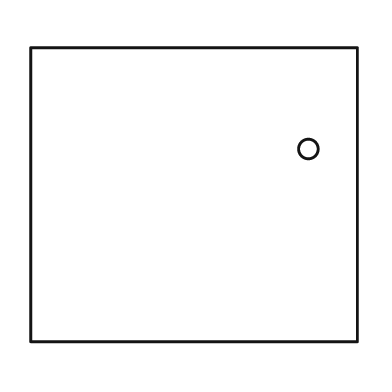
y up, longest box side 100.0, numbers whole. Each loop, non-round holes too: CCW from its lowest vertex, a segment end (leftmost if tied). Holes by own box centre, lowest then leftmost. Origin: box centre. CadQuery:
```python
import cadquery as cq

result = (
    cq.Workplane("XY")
    .moveTo(-50.0, -45.0)
    .lineTo(50.0, -45.0)
    .lineTo(50.0, 45.0)
    .lineTo(-50.0, 45.0)
    .close()
    .moveTo(35.0, 14.0)
    .circle(3.0)
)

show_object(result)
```